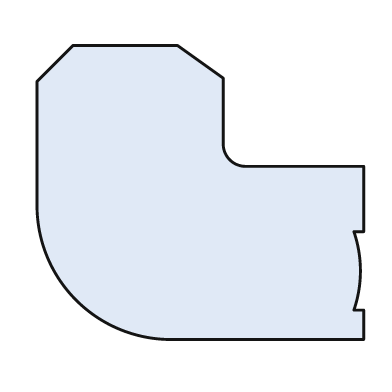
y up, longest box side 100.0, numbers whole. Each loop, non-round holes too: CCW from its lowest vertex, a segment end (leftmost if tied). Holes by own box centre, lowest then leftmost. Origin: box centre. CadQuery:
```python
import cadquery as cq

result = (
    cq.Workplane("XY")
    .moveTo(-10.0, -45.0)
    .lineTo(50.0, -45.0)
    .lineTo(50.0, -36.0)
    .lineTo(47.0, -36.0)
    .threePointArc((49.0, -24.0), (47.0, -12.0))
    .lineTo(50.0, -12.0)
    .lineTo(50.0, 8.0)
    .lineTo(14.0, 8.0)
    .threePointArc((9.0, 10.0), (7.0, 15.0))
    .lineTo(7.0, 35.0)
    .lineTo(-7.0, 45.0)
    .lineTo(-39.0, 45.0)
    .lineTo(-50.0, 34.0)
    .lineTo(-50.0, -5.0)
    .threePointArc((-38.0, -33.0), (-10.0, -45.0))
    .close()
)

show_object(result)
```